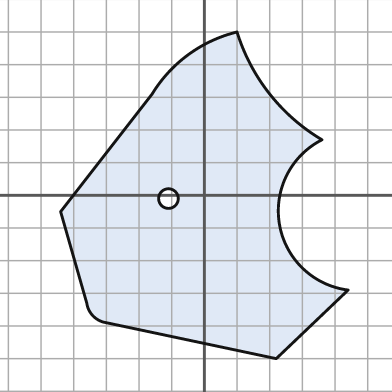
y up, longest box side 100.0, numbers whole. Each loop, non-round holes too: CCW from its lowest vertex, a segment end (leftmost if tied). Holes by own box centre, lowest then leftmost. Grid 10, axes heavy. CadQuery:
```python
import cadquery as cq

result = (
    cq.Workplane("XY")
    .moveTo(22.0, -50.0)
    .lineTo(44.0, -29.0)
    .threePointArc((23.0, -9.0), (36.0, 17.0))
    .threePointArc((20.0, 31.0), (10.0, 50.0))
    .threePointArc((-5.0, 43.0), (-16.0, 31.0))
    .lineTo(-44.0, -5.0)
    .lineTo(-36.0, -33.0)
    .threePointArc((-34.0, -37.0), (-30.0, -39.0))
    .close()
    .moveTo(-11.0, -1.0)
    .circle(3.0)
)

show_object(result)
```